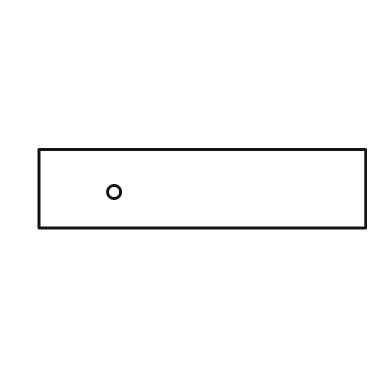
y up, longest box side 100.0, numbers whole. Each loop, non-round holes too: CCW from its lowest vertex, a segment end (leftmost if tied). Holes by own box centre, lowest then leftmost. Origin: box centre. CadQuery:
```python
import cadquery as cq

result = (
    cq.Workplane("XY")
    .moveTo(-50.0, -12.0)
    .lineTo(50.0, -12.0)
    .lineTo(50.0, 12.0)
    .lineTo(-50.0, 12.0)
    .close()
    .moveTo(-27.0, -1.0)
    .circle(2.0)
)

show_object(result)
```